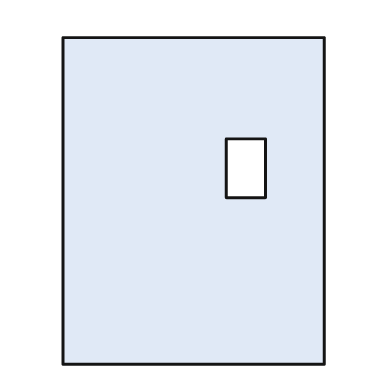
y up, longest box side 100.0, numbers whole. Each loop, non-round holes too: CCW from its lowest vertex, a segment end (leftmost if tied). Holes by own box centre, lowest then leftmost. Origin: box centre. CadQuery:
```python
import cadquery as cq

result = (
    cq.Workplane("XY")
    .moveTo(-40.0, -50.0)
    .lineTo(40.0, -50.0)
    .lineTo(40.0, 50.0)
    .lineTo(-40.0, 50.0)
    .close()
    .moveTo(10.0, 1.0)
    .lineTo(22.0, 1.0)
    .lineTo(22.0, 19.0)
    .lineTo(10.0, 19.0)
    .close()
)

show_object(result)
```